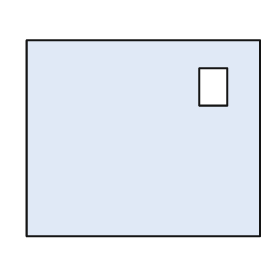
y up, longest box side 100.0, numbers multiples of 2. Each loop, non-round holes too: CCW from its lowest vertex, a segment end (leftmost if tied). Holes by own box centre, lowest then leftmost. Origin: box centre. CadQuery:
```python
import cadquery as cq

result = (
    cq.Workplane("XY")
    .moveTo(-50.0, -42.0)
    .lineTo(50.0, -42.0)
    .lineTo(50.0, 42.0)
    .lineTo(-50.0, 42.0)
    .close()
    .moveTo(24.0, 14.0)
    .lineTo(36.0, 14.0)
    .lineTo(36.0, 30.0)
    .lineTo(24.0, 30.0)
    .close()
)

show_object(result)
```